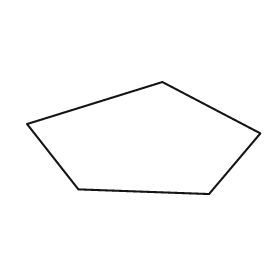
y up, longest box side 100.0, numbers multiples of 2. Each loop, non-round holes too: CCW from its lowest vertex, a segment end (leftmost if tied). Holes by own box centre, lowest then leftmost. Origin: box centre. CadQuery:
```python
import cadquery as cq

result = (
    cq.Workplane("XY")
    .moveTo(28.0, -24.0)
    .lineTo(50.0, 2.0)
    .lineTo(8.0, 24.0)
    .lineTo(-50.0, 6.0)
    .lineTo(-28.0, -22.0)
    .close()
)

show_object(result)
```